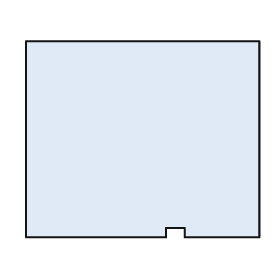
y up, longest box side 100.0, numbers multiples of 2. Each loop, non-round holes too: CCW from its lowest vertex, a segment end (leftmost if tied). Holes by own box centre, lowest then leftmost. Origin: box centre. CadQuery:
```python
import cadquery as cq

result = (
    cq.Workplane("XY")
    .moveTo(-50.0, -42.0)
    .lineTo(10.0, -42.0)
    .lineTo(10.0, -38.0)
    .lineTo(18.0, -38.0)
    .lineTo(18.0, -42.0)
    .lineTo(50.0, -42.0)
    .lineTo(50.0, 42.0)
    .lineTo(-50.0, 42.0)
    .close()
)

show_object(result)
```